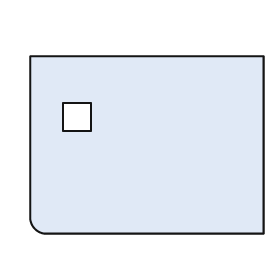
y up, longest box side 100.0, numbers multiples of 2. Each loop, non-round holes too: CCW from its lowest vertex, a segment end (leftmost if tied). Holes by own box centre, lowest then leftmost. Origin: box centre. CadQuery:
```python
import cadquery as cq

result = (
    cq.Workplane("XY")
    .moveTo(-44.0, -38.0)
    .lineTo(50.0, -38.0)
    .lineTo(50.0, 38.0)
    .lineTo(-50.0, 38.0)
    .lineTo(-50.0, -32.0)
    .threePointArc((-48.0, -36.0), (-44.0, -38.0))
    .close()
    .moveTo(-36.0, 6.0)
    .lineTo(-24.0, 6.0)
    .lineTo(-24.0, 18.0)
    .lineTo(-36.0, 18.0)
    .close()
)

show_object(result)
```